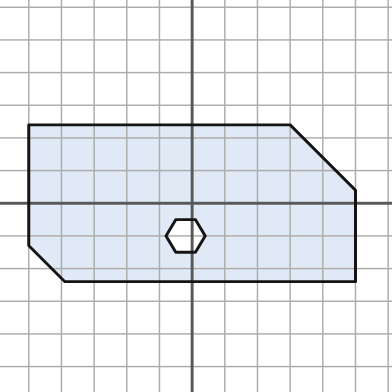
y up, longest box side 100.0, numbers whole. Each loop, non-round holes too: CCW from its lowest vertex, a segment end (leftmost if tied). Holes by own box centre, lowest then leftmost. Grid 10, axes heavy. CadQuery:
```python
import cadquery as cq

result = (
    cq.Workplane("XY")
    .moveTo(-39.0, -24.0)
    .lineTo(50.0, -24.0)
    .lineTo(50.0, 4.0)
    .lineTo(30.0, 24.0)
    .lineTo(-50.0, 24.0)
    .lineTo(-50.0, -13.0)
    .close()
    .moveTo(-5.0, -15.0)
    .lineTo(1.0, -15.0)
    .lineTo(4.0, -10.0)
    .lineTo(1.0, -5.0)
    .lineTo(-5.0, -5.0)
    .lineTo(-8.0, -10.0)
    .close()
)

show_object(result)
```